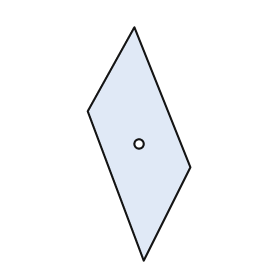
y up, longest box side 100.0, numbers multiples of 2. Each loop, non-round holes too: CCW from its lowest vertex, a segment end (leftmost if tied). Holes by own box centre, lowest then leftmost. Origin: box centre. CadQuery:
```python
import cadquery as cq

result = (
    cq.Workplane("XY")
    .moveTo(2.0, -50.0)
    .lineTo(22.0, -10.0)
    .lineTo(-2.0, 50.0)
    .lineTo(-22.0, 14.0)
    .close()
    .moveTo(0.0, 0.0)
    .circle(2.0)
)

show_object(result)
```